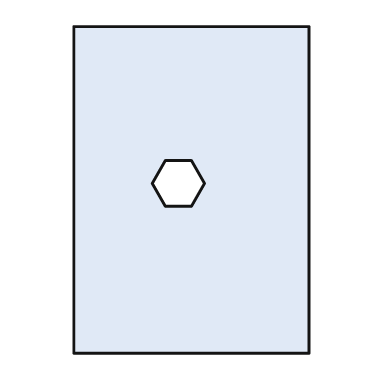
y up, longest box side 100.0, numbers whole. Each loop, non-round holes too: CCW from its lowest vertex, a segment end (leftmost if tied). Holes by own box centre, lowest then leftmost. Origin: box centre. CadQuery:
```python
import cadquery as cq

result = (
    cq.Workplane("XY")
    .moveTo(-36.0, -50.0)
    .lineTo(36.0, -50.0)
    .lineTo(36.0, 50.0)
    .lineTo(-36.0, 50.0)
    .close()
    .moveTo(-8.0, -5.0)
    .lineTo(0.0, -5.0)
    .lineTo(4.0, 2.0)
    .lineTo(0.0, 9.0)
    .lineTo(-8.0, 9.0)
    .lineTo(-12.0, 2.0)
    .close()
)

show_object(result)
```